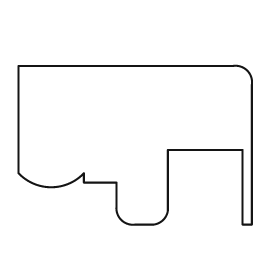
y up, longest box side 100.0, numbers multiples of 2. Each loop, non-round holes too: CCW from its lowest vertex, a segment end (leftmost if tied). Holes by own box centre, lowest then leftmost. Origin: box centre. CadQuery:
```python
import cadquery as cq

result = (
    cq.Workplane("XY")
    .moveTo(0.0, -34.0)
    .lineTo(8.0, -34.0)
    .threePointArc((12.0, -32.0), (14.0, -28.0))
    .lineTo(14.0, -2.0)
    .lineTo(46.0, -2.0)
    .lineTo(46.0, -34.0)
    .lineTo(50.0, -34.0)
    .lineTo(50.0, 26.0)
    .threePointArc((48.0, 32.0), (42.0, 34.0))
    .lineTo(-50.0, 34.0)
    .lineTo(-50.0, -12.0)
    .threePointArc((-36.0, -18.0), (-22.0, -12.0))
    .lineTo(-22.0, -16.0)
    .lineTo(-8.0, -16.0)
    .lineTo(-8.0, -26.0)
    .threePointArc((-6.0, -32.0), (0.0, -34.0))
    .close()
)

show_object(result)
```